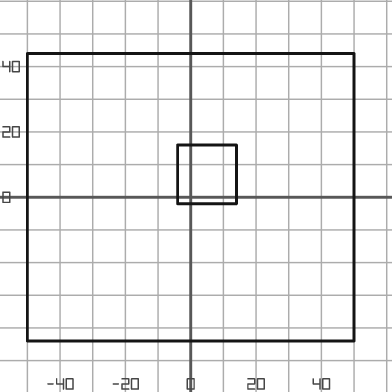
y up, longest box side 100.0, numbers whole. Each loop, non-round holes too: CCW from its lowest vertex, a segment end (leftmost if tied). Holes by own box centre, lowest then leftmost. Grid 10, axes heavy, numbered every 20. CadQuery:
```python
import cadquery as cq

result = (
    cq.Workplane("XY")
    .moveTo(-50.0, -44.0)
    .lineTo(50.0, -44.0)
    .lineTo(50.0, 44.0)
    .lineTo(-50.0, 44.0)
    .close()
    .moveTo(-4.0, -2.0)
    .lineTo(14.0, -2.0)
    .lineTo(14.0, 16.0)
    .lineTo(-4.0, 16.0)
    .close()
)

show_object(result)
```